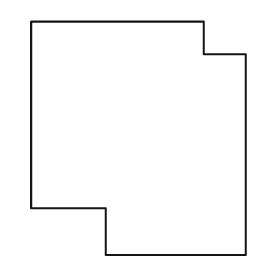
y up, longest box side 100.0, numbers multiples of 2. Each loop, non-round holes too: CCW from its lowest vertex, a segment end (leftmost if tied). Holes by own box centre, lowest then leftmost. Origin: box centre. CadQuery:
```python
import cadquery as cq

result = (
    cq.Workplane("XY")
    .moveTo(-14.0, -50.0)
    .lineTo(46.0, -50.0)
    .lineTo(46.0, 36.0)
    .lineTo(28.0, 36.0)
    .lineTo(28.0, 50.0)
    .lineTo(-46.0, 50.0)
    .lineTo(-46.0, -30.0)
    .lineTo(-14.0, -30.0)
    .close()
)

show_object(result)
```